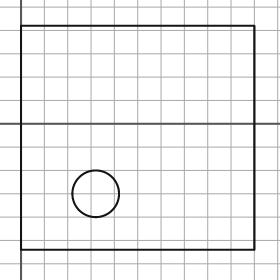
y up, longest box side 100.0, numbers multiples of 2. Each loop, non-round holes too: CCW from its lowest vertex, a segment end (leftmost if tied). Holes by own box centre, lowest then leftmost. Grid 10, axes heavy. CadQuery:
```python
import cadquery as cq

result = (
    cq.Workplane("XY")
    .moveTo(0.0, -54.0)
    .lineTo(100.0, -54.0)
    .lineTo(100.0, 42.0)
    .lineTo(0.0, 42.0)
    .close()
    .moveTo(32.0, -30.0)
    .circle(10.0)
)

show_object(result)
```